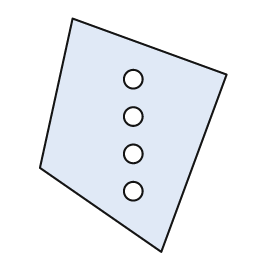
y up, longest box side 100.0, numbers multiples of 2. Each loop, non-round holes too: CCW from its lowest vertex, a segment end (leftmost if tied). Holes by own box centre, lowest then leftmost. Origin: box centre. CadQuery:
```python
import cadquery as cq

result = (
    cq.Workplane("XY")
    .moveTo(12.0, -50.0)
    .lineTo(40.0, 26.0)
    .lineTo(-26.0, 50.0)
    .lineTo(-40.0, -14.0)
    .close()
    .moveTo(0.0, -24.0)
    .circle(4.0)
    .moveTo(0.0, -8.0)
    .circle(4.0)
    .moveTo(0.0, 8.0)
    .circle(4.0)
    .moveTo(0.0, 24.0)
    .circle(4.0)
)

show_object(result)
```